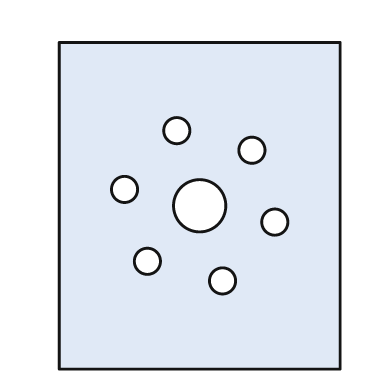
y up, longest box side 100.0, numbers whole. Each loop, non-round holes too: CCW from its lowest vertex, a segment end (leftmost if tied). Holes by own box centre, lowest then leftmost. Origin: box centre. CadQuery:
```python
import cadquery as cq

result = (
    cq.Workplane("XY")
    .moveTo(-43.0, -50.0)
    .lineTo(43.0, -50.0)
    .lineTo(43.0, 50.0)
    .lineTo(-43.0, 50.0)
    .close()
    .moveTo(7.0, -23.0)
    .circle(4.0)
    .moveTo(-16.0, -17.0)
    .circle(4.0)
    .moveTo(23.0, -5.0)
    .circle(4.0)
    .moveTo(0.0, 0.0)
    .circle(8.0)
    .moveTo(-23.0, 5.0)
    .circle(4.0)
    .moveTo(16.0, 17.0)
    .circle(4.0)
    .moveTo(-7.0, 23.0)
    .circle(4.0)
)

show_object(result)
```